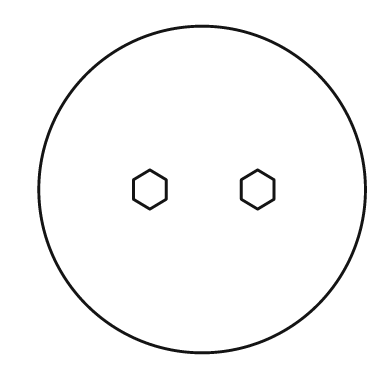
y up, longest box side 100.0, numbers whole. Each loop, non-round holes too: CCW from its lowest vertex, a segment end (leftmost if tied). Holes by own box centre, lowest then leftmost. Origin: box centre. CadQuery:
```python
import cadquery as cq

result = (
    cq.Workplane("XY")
    .moveTo(0.0, 0.0)
    .circle(50.0)
    .moveTo(-16.0, -6.0)
    .lineTo(-11.0, -3.0)
    .lineTo(-11.0, 3.0)
    .lineTo(-16.0, 6.0)
    .lineTo(-21.0, 3.0)
    .lineTo(-21.0, -3.0)
    .close()
    .moveTo(17.0, -6.0)
    .lineTo(22.0, -3.0)
    .lineTo(22.0, 3.0)
    .lineTo(17.0, 6.0)
    .lineTo(12.0, 3.0)
    .lineTo(12.0, -3.0)
    .close()
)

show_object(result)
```